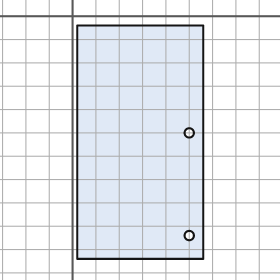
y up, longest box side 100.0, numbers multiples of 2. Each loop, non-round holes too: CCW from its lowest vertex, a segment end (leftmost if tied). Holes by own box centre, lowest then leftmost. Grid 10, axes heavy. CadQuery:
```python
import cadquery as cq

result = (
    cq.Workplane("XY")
    .moveTo(2.0, -104.0)
    .lineTo(56.0, -104.0)
    .lineTo(56.0, -4.0)
    .lineTo(2.0, -4.0)
    .close()
    .moveTo(50.0, -94.0)
    .circle(2.0)
    .moveTo(50.0, -50.0)
    .circle(2.0)
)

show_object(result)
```